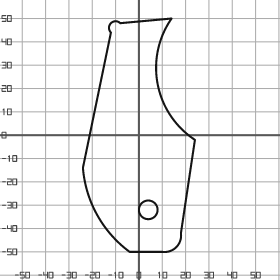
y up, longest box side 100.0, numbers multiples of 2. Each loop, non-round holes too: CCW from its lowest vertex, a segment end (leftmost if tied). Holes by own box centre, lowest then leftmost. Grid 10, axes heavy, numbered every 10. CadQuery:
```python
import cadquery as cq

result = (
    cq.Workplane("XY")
    .moveTo(-4.0, -50.0)
    .lineTo(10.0, -50.0)
    .threePointArc((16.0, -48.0), (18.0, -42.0))
    .lineTo(24.0, -2.0)
    .threePointArc((8.0, 22.0), (14.0, 50.0))
    .lineTo(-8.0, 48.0)
    .threePointArc((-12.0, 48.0), (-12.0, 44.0))
    .lineTo(-24.0, -14.0)
    .threePointArc((-18.0, -34.0), (-4.0, -50.0))
    .close()
    .moveTo(4.0, -32.0)
    .circle(4.0)
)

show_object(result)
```